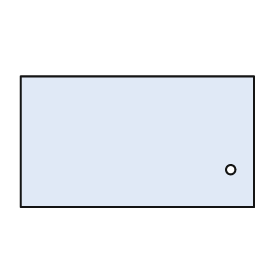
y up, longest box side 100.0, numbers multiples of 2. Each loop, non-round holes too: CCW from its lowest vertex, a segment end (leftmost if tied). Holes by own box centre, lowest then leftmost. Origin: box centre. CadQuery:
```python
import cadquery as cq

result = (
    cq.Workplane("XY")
    .moveTo(-50.0, -28.0)
    .lineTo(50.0, -28.0)
    .lineTo(50.0, 28.0)
    .lineTo(-50.0, 28.0)
    .close()
    .moveTo(40.0, -12.0)
    .circle(2.0)
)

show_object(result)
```